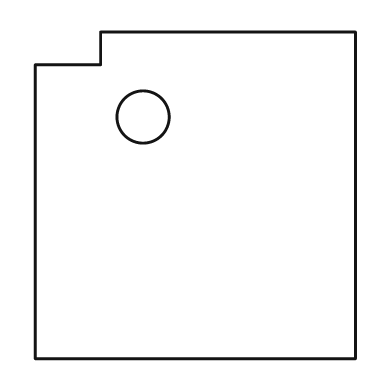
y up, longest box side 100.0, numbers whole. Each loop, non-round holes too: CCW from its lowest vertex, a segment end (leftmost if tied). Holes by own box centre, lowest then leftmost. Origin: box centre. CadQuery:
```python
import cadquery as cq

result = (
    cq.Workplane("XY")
    .moveTo(-49.0, -50.0)
    .lineTo(49.0, -50.0)
    .lineTo(49.0, 50.0)
    .lineTo(-29.0, 50.0)
    .lineTo(-29.0, 40.0)
    .lineTo(-49.0, 40.0)
    .close()
    .moveTo(-16.0, 24.0)
    .circle(8.0)
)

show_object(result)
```